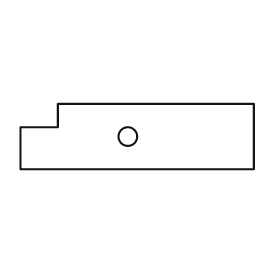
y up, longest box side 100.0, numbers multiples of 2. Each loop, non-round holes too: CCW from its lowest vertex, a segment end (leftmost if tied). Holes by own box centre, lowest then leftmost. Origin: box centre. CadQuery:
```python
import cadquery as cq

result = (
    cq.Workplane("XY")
    .moveTo(-50.0, -14.0)
    .lineTo(50.0, -14.0)
    .lineTo(50.0, 14.0)
    .lineTo(-34.0, 14.0)
    .lineTo(-34.0, 4.0)
    .lineTo(-50.0, 4.0)
    .close()
    .moveTo(-4.0, 0.0)
    .circle(4.0)
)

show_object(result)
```